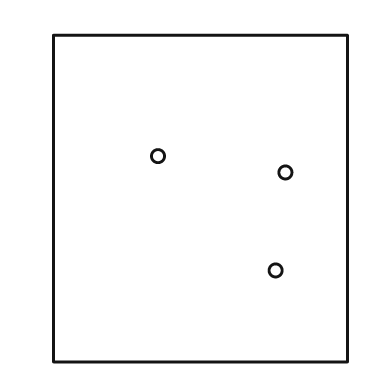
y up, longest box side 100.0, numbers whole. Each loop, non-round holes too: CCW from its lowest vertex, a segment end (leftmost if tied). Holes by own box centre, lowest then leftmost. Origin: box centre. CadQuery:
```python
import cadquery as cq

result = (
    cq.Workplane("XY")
    .moveTo(-45.0, -50.0)
    .lineTo(45.0, -50.0)
    .lineTo(45.0, 50.0)
    .lineTo(-45.0, 50.0)
    .close()
    .moveTo(23.0, -22.0)
    .circle(2.0)
    .moveTo(26.0, 8.0)
    .circle(2.0)
    .moveTo(-13.0, 13.0)
    .circle(2.0)
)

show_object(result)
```